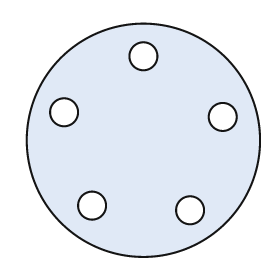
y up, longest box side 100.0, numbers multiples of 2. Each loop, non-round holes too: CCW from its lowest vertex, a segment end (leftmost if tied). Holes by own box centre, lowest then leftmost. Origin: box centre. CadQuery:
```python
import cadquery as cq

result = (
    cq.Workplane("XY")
    .moveTo(0.0, 0.0)
    .circle(50.0)
    .moveTo(20.0, -30.0)
    .circle(6.0)
    .moveTo(-22.0, -28.0)
    .circle(6.0)
    .moveTo(34.0, 10.0)
    .circle(6.0)
    .moveTo(-34.0, 12.0)
    .circle(6.0)
    .moveTo(0.0, 36.0)
    .circle(6.0)
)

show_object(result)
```